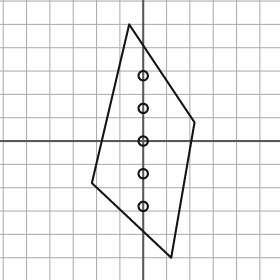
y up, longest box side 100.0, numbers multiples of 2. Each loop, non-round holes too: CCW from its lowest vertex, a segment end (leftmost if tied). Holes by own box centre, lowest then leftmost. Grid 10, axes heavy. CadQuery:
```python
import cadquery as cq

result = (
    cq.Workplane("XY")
    .moveTo(12.0, -50.0)
    .lineTo(22.0, 8.0)
    .lineTo(-6.0, 50.0)
    .lineTo(-22.0, -18.0)
    .close()
    .moveTo(0.0, -28.0)
    .circle(2.0)
    .moveTo(0.0, -14.0)
    .circle(2.0)
    .moveTo(0.0, 0.0)
    .circle(2.0)
    .moveTo(0.0, 14.0)
    .circle(2.0)
    .moveTo(0.0, 28.0)
    .circle(2.0)
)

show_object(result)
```